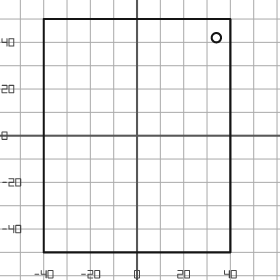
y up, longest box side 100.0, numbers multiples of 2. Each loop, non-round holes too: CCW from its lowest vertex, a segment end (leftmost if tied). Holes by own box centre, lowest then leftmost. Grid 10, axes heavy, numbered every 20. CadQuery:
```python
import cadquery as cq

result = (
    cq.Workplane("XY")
    .moveTo(-40.0, -50.0)
    .lineTo(40.0, -50.0)
    .lineTo(40.0, 50.0)
    .lineTo(-40.0, 50.0)
    .close()
    .moveTo(34.0, 42.0)
    .circle(2.0)
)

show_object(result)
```